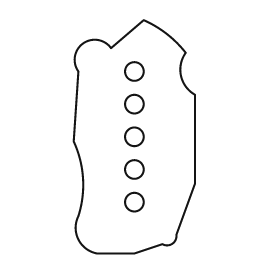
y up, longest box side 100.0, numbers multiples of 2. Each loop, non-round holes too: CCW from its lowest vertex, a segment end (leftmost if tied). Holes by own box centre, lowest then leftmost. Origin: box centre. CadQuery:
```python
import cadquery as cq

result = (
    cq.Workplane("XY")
    .moveTo(-16.0, -50.0)
    .lineTo(0.0, -50.0)
    .lineTo(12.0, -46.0)
    .threePointArc((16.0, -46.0), (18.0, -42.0))
    .lineTo(26.0, -20.0)
    .lineTo(26.0, 18.0)
    .threePointArc((20.0, 26.0), (22.0, 36.0))
    .threePointArc((14.0, 44.0), (4.0, 50.0))
    .lineTo(-10.0, 38.0)
    .threePointArc((-22.0, 40.0), (-24.0, 28.0))
    .lineTo(-26.0, -2.0)
    .threePointArc((-22.0, -18.0), (-24.0, -34.0))
    .threePointArc((-24.0, -44.0), (-16.0, -50.0))
    .close()
    .moveTo(0.0, -28.0)
    .circle(4.0)
    .moveTo(0.0, -14.0)
    .circle(4.0)
    .moveTo(0.0, 0.0)
    .circle(4.0)
    .moveTo(0.0, 14.0)
    .circle(4.0)
    .moveTo(0.0, 28.0)
    .circle(4.0)
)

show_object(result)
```